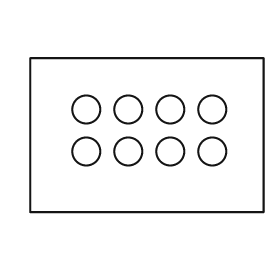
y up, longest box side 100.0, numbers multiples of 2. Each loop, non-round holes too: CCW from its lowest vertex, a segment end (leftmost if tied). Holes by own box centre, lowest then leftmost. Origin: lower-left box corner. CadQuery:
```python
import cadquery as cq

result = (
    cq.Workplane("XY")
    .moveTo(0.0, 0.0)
    .lineTo(100.0, 0.0)
    .lineTo(100.0, 66.0)
    .lineTo(0.0, 66.0)
    .close()
    .moveTo(24.0, 26.0)
    .circle(6.0)
    .moveTo(42.0, 26.0)
    .circle(6.0)
    .moveTo(60.0, 26.0)
    .circle(6.0)
    .moveTo(78.0, 26.0)
    .circle(6.0)
    .moveTo(24.0, 44.0)
    .circle(6.0)
    .moveTo(42.0, 44.0)
    .circle(6.0)
    .moveTo(60.0, 44.0)
    .circle(6.0)
    .moveTo(78.0, 44.0)
    .circle(6.0)
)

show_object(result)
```